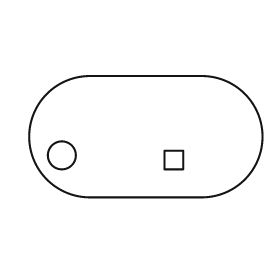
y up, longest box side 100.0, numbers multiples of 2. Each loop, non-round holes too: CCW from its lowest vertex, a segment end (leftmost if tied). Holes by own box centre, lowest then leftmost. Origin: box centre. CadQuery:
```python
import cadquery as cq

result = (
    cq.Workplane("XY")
    .moveTo(-24.0, -26.0)
    .lineTo(24.0, -26.0)
    .threePointArc((50.0, 0.0), (24.0, 26.0))
    .lineTo(-24.0, 26.0)
    .threePointArc((-50.0, 0.0), (-24.0, -26.0))
    .close()
    .moveTo(8.0, -14.0)
    .lineTo(16.0, -14.0)
    .lineTo(16.0, -6.0)
    .lineTo(8.0, -6.0)
    .close()
    .moveTo(-36.0, -8.0)
    .circle(6.0)
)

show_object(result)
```